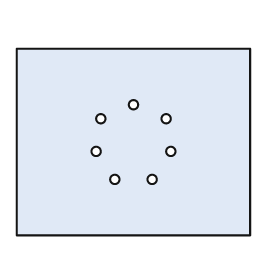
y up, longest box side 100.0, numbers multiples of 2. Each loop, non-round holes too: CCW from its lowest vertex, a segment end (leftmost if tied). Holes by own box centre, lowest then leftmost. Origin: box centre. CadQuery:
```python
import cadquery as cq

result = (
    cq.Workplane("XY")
    .moveTo(-50.0, -40.0)
    .lineTo(50.0, -40.0)
    .lineTo(50.0, 40.0)
    .lineTo(-50.0, 40.0)
    .close()
    .moveTo(-8.0, -16.0)
    .circle(2.0)
    .moveTo(8.0, -16.0)
    .circle(2.0)
    .moveTo(-16.0, -4.0)
    .circle(2.0)
    .moveTo(16.0, -4.0)
    .circle(2.0)
    .moveTo(-14.0, 10.0)
    .circle(2.0)
    .moveTo(14.0, 10.0)
    .circle(2.0)
    .moveTo(0.0, 16.0)
    .circle(2.0)
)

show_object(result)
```